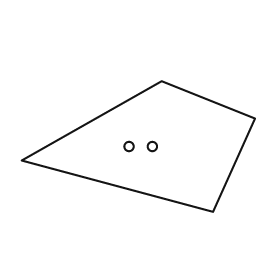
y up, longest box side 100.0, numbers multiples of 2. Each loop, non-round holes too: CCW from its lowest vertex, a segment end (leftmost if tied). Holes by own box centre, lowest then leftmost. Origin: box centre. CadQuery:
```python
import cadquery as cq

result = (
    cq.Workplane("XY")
    .moveTo(32.0, -28.0)
    .lineTo(50.0, 12.0)
    .lineTo(10.0, 28.0)
    .lineTo(-50.0, -6.0)
    .close()
    .moveTo(-4.0, 0.0)
    .circle(2.0)
    .moveTo(6.0, 0.0)
    .circle(2.0)
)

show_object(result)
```